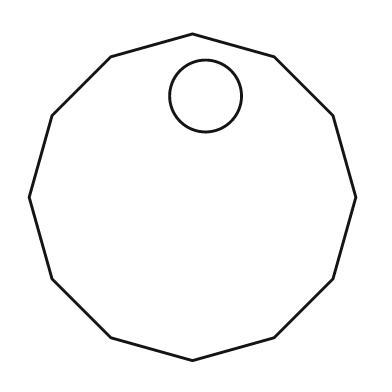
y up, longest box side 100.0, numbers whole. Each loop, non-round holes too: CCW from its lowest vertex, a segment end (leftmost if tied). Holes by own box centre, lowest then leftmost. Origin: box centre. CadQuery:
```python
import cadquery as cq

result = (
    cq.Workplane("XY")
    .moveTo(0.0, -50.0)
    .lineTo(25.0, -43.0)
    .lineTo(43.0, -25.0)
    .lineTo(50.0, 0.0)
    .lineTo(43.0, 25.0)
    .lineTo(25.0, 43.0)
    .lineTo(0.0, 50.0)
    .lineTo(-25.0, 43.0)
    .lineTo(-43.0, 25.0)
    .lineTo(-50.0, 0.0)
    .lineTo(-43.0, -25.0)
    .lineTo(-25.0, -43.0)
    .close()
    .moveTo(4.0, 31.0)
    .circle(11.0)
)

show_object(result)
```